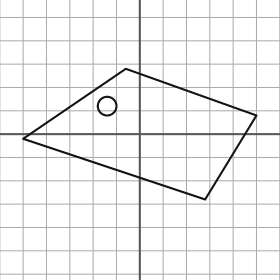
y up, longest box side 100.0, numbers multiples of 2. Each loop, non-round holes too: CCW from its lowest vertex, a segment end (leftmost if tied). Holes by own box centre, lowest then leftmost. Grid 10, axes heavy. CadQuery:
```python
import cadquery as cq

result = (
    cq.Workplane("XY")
    .moveTo(28.0, -28.0)
    .lineTo(50.0, 8.0)
    .lineTo(-6.0, 28.0)
    .lineTo(-50.0, -2.0)
    .close()
    .moveTo(-14.0, 12.0)
    .circle(4.0)
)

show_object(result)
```